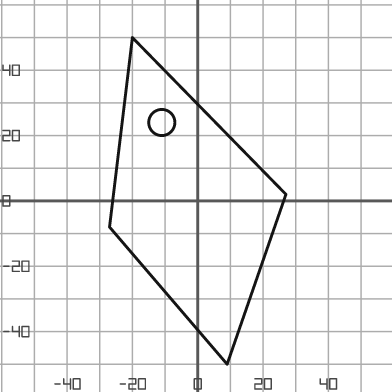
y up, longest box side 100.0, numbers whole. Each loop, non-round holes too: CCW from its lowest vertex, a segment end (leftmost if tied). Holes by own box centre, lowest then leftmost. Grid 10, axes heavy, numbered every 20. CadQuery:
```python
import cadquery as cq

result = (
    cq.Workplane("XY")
    .moveTo(9.0, -50.0)
    .lineTo(27.0, 2.0)
    .lineTo(-20.0, 50.0)
    .lineTo(-27.0, -8.0)
    .close()
    .moveTo(-11.0, 24.0)
    .circle(4.0)
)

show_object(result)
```